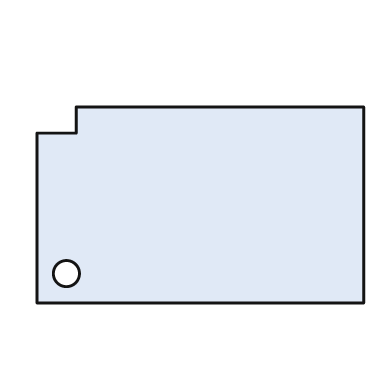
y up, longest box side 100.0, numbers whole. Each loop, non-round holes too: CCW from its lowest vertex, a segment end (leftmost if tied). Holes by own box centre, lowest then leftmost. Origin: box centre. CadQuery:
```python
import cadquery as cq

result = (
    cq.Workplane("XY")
    .moveTo(-50.0, -30.0)
    .lineTo(50.0, -30.0)
    .lineTo(50.0, 30.0)
    .lineTo(-38.0, 30.0)
    .lineTo(-38.0, 22.0)
    .lineTo(-50.0, 22.0)
    .close()
    .moveTo(-41.0, -21.0)
    .circle(4.0)
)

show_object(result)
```